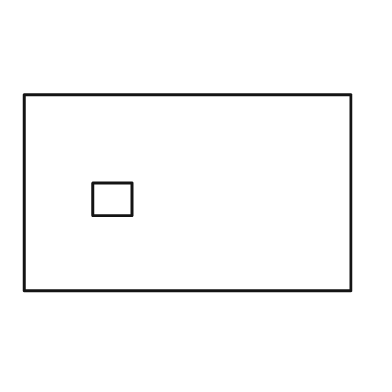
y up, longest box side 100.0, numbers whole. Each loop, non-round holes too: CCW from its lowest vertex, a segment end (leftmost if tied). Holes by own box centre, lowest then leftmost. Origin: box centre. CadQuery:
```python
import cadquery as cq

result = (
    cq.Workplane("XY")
    .moveTo(-50.0, -30.0)
    .lineTo(50.0, -30.0)
    .lineTo(50.0, 30.0)
    .lineTo(-50.0, 30.0)
    .close()
    .moveTo(-29.0, -7.0)
    .lineTo(-17.0, -7.0)
    .lineTo(-17.0, 3.0)
    .lineTo(-29.0, 3.0)
    .close()
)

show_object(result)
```